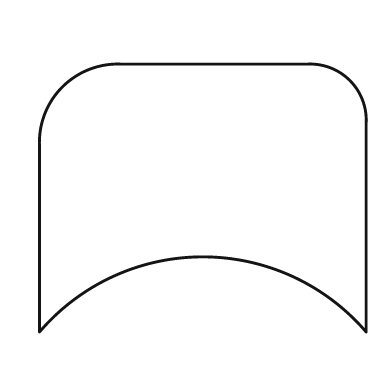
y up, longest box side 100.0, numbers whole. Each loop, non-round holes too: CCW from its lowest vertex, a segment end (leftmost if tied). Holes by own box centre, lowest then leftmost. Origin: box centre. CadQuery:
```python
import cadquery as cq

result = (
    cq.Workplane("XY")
    .moveTo(-50.0, -41.0)
    .threePointArc((0.0, -18.0), (50.0, -41.0))
    .lineTo(50.0, 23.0)
    .threePointArc((45.0, 36.0), (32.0, 41.0))
    .lineTo(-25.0, 41.0)
    .threePointArc((-43.0, 34.0), (-50.0, 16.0))
    .close()
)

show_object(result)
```